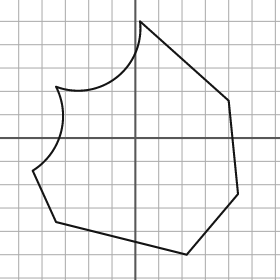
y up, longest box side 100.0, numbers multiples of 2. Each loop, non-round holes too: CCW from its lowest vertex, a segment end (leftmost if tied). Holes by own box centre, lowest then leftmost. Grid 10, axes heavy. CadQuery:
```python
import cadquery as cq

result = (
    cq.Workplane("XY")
    .moveTo(22.0, -50.0)
    .lineTo(44.0, -24.0)
    .lineTo(40.0, 16.0)
    .lineTo(2.0, 50.0)
    .threePointArc((-8.0, 26.0), (-34.0, 22.0))
    .threePointArc((-32.0, 2.0), (-44.0, -14.0))
    .lineTo(-34.0, -36.0)
    .close()
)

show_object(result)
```